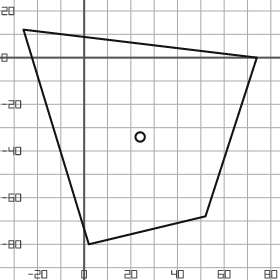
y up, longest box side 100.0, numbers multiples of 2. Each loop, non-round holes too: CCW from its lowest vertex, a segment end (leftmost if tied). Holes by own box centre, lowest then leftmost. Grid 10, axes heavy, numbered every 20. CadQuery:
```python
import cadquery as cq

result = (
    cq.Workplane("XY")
    .moveTo(2.0, -80.0)
    .lineTo(52.0, -68.0)
    .lineTo(74.0, 0.0)
    .lineTo(-26.0, 12.0)
    .close()
    .moveTo(24.0, -34.0)
    .circle(2.0)
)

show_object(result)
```